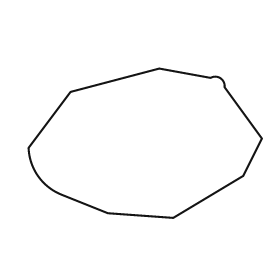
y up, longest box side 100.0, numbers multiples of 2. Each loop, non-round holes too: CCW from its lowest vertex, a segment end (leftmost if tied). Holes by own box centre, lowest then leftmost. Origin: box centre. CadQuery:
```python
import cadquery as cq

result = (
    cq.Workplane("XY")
    .moveTo(12.0, -32.0)
    .lineTo(42.0, -14.0)
    .lineTo(50.0, 2.0)
    .lineTo(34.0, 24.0)
    .threePointArc((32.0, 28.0), (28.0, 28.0))
    .lineTo(6.0, 32.0)
    .lineTo(-32.0, 22.0)
    .lineTo(-50.0, -2.0)
    .threePointArc((-46.0, -14.0), (-36.0, -22.0))
    .lineTo(-16.0, -30.0)
    .close()
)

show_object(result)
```